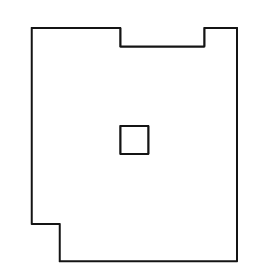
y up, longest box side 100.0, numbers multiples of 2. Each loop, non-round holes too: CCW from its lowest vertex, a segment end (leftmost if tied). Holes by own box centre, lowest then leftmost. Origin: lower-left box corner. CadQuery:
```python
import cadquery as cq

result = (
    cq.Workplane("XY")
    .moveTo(12.0, 0.0)
    .lineTo(88.0, 0.0)
    .lineTo(88.0, 100.0)
    .lineTo(74.0, 100.0)
    .lineTo(74.0, 92.0)
    .lineTo(38.0, 92.0)
    .lineTo(38.0, 100.0)
    .lineTo(0.0, 100.0)
    .lineTo(0.0, 16.0)
    .lineTo(12.0, 16.0)
    .close()
    .moveTo(38.0, 46.0)
    .lineTo(50.0, 46.0)
    .lineTo(50.0, 58.0)
    .lineTo(38.0, 58.0)
    .close()
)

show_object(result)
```